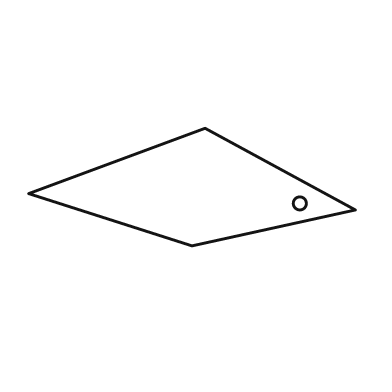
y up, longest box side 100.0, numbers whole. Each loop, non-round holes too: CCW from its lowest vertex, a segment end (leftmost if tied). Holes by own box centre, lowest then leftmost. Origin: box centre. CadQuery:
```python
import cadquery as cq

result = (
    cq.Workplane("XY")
    .moveTo(0.0, -18.0)
    .lineTo(50.0, -7.0)
    .lineTo(4.0, 18.0)
    .lineTo(-50.0, -2.0)
    .close()
    .moveTo(33.0, -5.0)
    .circle(2.0)
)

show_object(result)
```